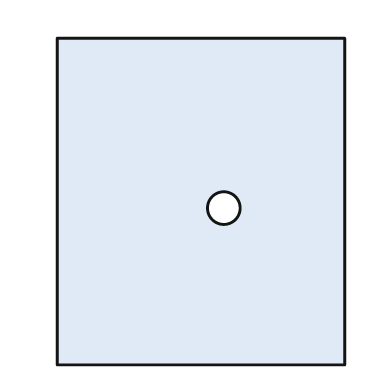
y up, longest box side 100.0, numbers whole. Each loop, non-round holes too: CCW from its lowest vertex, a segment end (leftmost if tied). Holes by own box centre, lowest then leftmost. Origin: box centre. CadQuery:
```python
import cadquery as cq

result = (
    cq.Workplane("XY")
    .moveTo(-44.0, -50.0)
    .lineTo(44.0, -50.0)
    .lineTo(44.0, 50.0)
    .lineTo(-44.0, 50.0)
    .close()
    .moveTo(7.0, -2.0)
    .circle(5.0)
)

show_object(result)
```